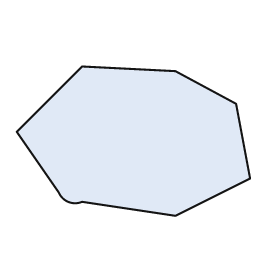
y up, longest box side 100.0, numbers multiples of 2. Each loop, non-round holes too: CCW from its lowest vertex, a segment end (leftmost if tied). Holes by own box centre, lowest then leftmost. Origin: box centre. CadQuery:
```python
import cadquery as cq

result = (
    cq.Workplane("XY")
    .moveTo(18.0, -32.0)
    .lineTo(50.0, -16.0)
    .lineTo(44.0, 16.0)
    .lineTo(18.0, 30.0)
    .lineTo(-22.0, 32.0)
    .lineTo(-50.0, 4.0)
    .lineTo(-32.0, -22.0)
    .threePointArc((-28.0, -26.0), (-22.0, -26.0))
    .close()
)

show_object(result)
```